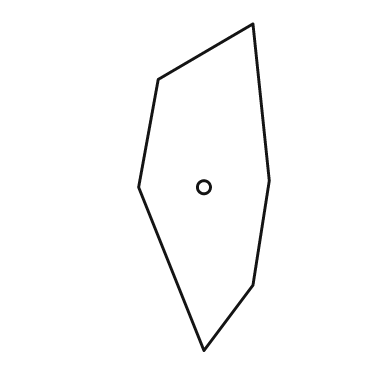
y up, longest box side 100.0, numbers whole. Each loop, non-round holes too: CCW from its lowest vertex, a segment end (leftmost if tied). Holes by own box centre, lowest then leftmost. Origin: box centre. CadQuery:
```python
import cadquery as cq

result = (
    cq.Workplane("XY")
    .moveTo(0.0, -50.0)
    .lineTo(15.0, -30.0)
    .lineTo(20.0, 2.0)
    .lineTo(15.0, 50.0)
    .lineTo(-14.0, 33.0)
    .lineTo(-20.0, 0.0)
    .close()
    .moveTo(0.0, 0.0)
    .circle(2.0)
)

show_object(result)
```